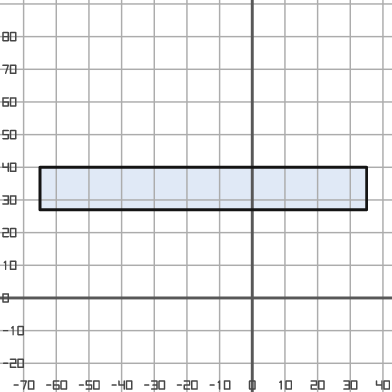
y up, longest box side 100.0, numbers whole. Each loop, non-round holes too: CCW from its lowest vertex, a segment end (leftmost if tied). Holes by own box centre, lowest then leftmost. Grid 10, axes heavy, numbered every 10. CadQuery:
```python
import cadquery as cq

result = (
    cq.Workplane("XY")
    .moveTo(-65.0, 27.0)
    .lineTo(35.0, 27.0)
    .lineTo(35.0, 40.0)
    .lineTo(-65.0, 40.0)
    .close()
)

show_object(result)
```